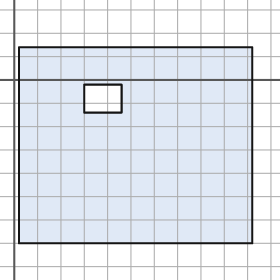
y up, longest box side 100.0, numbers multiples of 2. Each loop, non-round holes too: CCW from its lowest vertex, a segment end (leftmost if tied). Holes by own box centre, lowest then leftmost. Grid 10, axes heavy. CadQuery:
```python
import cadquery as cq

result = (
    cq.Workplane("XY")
    .moveTo(2.0, -70.0)
    .lineTo(102.0, -70.0)
    .lineTo(102.0, 14.0)
    .lineTo(2.0, 14.0)
    .close()
    .moveTo(30.0, -14.0)
    .lineTo(46.0, -14.0)
    .lineTo(46.0, -2.0)
    .lineTo(30.0, -2.0)
    .close()
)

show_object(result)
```